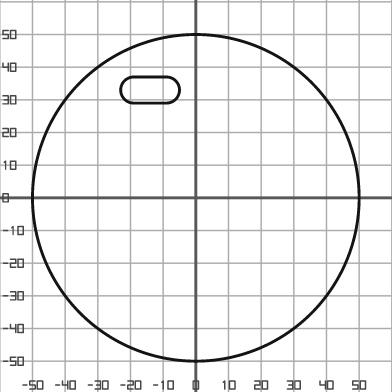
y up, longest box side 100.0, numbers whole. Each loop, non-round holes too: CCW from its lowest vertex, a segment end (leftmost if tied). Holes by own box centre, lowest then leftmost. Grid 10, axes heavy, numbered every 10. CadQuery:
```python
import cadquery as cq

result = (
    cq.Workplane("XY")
    .moveTo(0.0, 0.0)
    .circle(50.0)
    .moveTo(-19.0, 29.0)
    .lineTo(-9.0, 29.0)
    .threePointArc((-5.0, 33.0), (-9.0, 37.0))
    .lineTo(-19.0, 37.0)
    .threePointArc((-23.0, 33.0), (-19.0, 29.0))
    .close()
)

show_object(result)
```